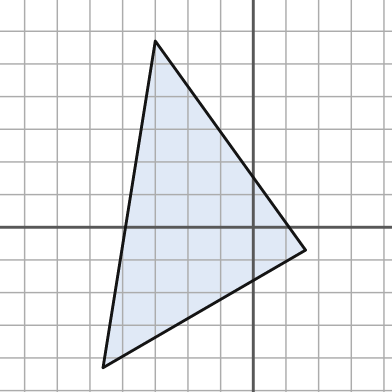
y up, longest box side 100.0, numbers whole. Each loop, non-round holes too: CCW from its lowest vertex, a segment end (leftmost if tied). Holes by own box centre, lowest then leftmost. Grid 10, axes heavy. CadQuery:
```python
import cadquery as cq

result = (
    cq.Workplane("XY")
    .moveTo(-46.0, -43.0)
    .lineTo(16.0, -7.0)
    .lineTo(-30.0, 57.0)
    .close()
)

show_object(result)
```